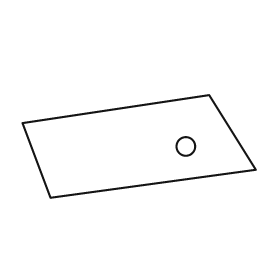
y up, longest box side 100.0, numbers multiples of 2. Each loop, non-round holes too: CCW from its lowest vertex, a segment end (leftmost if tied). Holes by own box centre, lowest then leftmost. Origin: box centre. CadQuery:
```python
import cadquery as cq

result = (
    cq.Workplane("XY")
    .moveTo(-38.0, -22.0)
    .lineTo(50.0, -10.0)
    .lineTo(30.0, 22.0)
    .lineTo(-50.0, 10.0)
    .close()
    .moveTo(20.0, 0.0)
    .circle(4.0)
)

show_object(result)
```